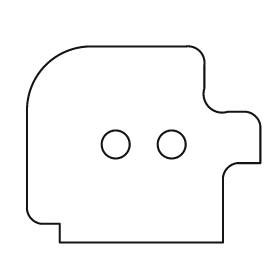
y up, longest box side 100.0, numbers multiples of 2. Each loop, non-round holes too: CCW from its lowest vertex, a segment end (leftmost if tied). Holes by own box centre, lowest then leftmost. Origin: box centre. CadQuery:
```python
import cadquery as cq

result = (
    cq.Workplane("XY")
    .moveTo(-36.0, -42.0)
    .lineTo(34.0, -42.0)
    .lineTo(34.0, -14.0)
    .threePointArc((36.0, -10.0), (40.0, -8.0))
    .lineTo(50.0, -8.0)
    .lineTo(50.0, 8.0)
    .threePointArc((48.0, 12.0), (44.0, 14.0))
    .lineTo(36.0, 14.0)
    .threePointArc((28.0, 16.0), (26.0, 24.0))
    .lineTo(26.0, 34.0)
    .threePointArc((24.0, 40.0), (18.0, 42.0))
    .lineTo(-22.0, 42.0)
    .threePointArc((-42.0, 34.0), (-50.0, 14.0))
    .lineTo(-50.0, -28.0)
    .threePointArc((-48.0, -32.0), (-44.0, -34.0))
    .lineTo(-36.0, -34.0)
    .close()
    .moveTo(-12.0, 0.0)
    .circle(6.0)
    .moveTo(12.0, 0.0)
    .circle(6.0)
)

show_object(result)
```